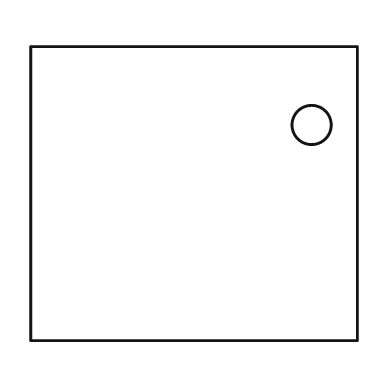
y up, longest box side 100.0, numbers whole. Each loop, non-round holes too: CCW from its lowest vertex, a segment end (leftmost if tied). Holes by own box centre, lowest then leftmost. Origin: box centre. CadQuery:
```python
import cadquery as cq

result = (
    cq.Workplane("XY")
    .moveTo(-50.0, -45.0)
    .lineTo(50.0, -45.0)
    .lineTo(50.0, 45.0)
    .lineTo(-50.0, 45.0)
    .close()
    .moveTo(36.0, 21.0)
    .circle(6.0)
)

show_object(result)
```